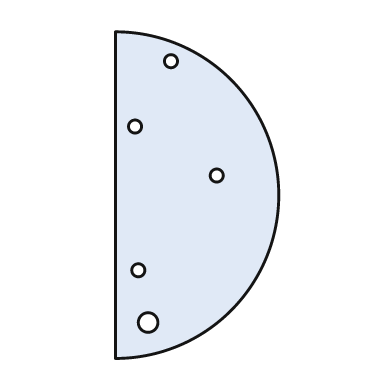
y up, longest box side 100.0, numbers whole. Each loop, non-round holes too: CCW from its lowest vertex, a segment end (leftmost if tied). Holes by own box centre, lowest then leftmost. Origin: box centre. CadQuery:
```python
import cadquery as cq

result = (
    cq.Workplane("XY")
    .moveTo(-25.0, -50.0)
    .threePointArc((25.0, 0.0), (-25.0, 50.0))
    .close()
    .moveTo(-15.0, -39.0)
    .circle(3.0)
    .moveTo(-18.0, -23.0)
    .circle(2.0)
    .moveTo(6.0, 6.0)
    .circle(2.0)
    .moveTo(-19.0, 21.0)
    .circle(2.0)
    .moveTo(-8.0, 41.0)
    .circle(2.0)
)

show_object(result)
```